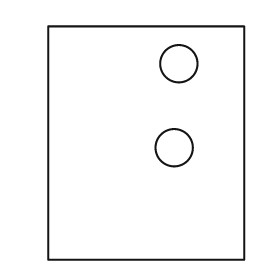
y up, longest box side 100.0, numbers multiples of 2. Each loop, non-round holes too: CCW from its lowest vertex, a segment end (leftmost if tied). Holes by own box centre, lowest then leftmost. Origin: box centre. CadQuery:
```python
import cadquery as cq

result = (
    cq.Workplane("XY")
    .moveTo(-42.0, -50.0)
    .lineTo(42.0, -50.0)
    .lineTo(42.0, 50.0)
    .lineTo(-42.0, 50.0)
    .close()
    .moveTo(12.0, -2.0)
    .circle(8.0)
    .moveTo(14.0, 34.0)
    .circle(8.0)
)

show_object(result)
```